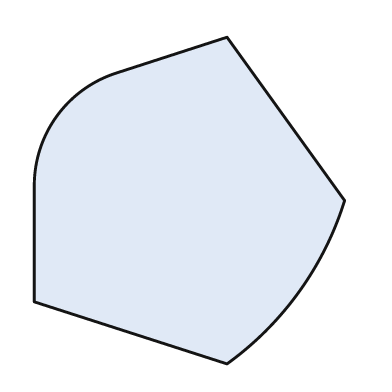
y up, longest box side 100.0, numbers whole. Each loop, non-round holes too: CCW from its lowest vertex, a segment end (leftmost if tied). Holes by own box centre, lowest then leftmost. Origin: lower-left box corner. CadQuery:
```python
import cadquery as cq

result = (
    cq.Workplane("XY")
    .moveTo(59.0, 0.0)
    .threePointArc((81.0, 22.0), (95.0, 50.0))
    .lineTo(59.0, 100.0)
    .lineTo(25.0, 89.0)
    .threePointArc((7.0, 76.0), (0.0, 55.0))
    .lineTo(0.0, 19.0)
    .close()
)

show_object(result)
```